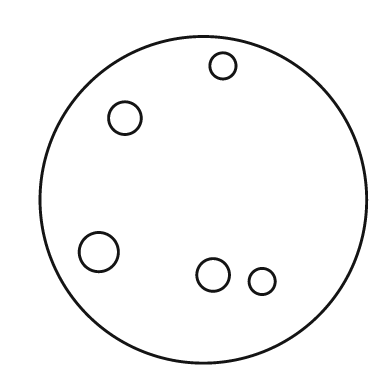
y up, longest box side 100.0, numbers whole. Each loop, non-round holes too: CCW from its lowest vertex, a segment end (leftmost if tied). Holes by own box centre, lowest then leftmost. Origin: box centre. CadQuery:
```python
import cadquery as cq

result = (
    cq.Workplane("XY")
    .moveTo(0.0, 0.0)
    .circle(50.0)
    .moveTo(18.0, -25.0)
    .circle(4.0)
    .moveTo(3.0, -23.0)
    .circle(5.0)
    .moveTo(-32.0, -16.0)
    .circle(6.0)
    .moveTo(-24.0, 25.0)
    .circle(5.0)
    .moveTo(6.0, 41.0)
    .circle(4.0)
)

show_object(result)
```